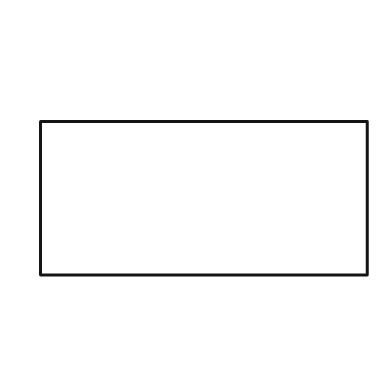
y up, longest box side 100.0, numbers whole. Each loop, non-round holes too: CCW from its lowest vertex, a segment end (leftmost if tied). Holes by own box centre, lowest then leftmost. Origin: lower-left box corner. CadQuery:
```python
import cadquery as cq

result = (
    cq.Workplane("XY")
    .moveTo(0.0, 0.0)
    .lineTo(100.0, 0.0)
    .lineTo(100.0, 47.0)
    .lineTo(0.0, 47.0)
    .close()
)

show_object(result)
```